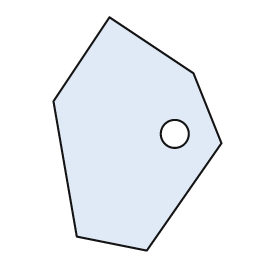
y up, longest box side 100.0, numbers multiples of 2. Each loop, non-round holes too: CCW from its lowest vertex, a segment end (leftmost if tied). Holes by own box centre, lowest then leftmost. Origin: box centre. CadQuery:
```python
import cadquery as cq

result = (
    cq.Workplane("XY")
    .moveTo(4.0, -50.0)
    .lineTo(36.0, -4.0)
    .lineTo(24.0, 26.0)
    .lineTo(-12.0, 50.0)
    .lineTo(-36.0, 14.0)
    .lineTo(-26.0, -44.0)
    .close()
    .moveTo(16.0, 0.0)
    .circle(6.0)
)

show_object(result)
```